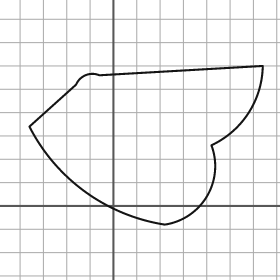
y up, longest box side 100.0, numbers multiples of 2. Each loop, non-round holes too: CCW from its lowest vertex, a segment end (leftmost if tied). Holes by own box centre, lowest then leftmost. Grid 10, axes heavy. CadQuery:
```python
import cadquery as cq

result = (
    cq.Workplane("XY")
    .moveTo(22.0, -8.0)
    .threePointArc((40.0, 4.0), (42.0, 26.0))
    .threePointArc((58.0, 40.0), (64.0, 60.0))
    .lineTo(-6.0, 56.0)
    .threePointArc((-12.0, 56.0), (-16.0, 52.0))
    .lineTo(-36.0, 34.0)
    .threePointArc((-12.0, 6.0), (22.0, -8.0))
    .close()
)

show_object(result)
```